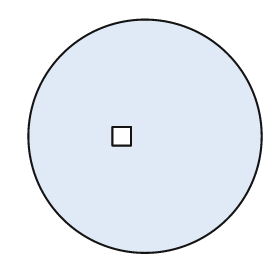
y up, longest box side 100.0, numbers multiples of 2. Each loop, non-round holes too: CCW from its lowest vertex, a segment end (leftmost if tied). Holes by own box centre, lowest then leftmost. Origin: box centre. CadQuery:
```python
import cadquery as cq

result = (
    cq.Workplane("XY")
    .moveTo(0.0, 0.0)
    .circle(50.0)
    .moveTo(-14.0, -4.0)
    .lineTo(-6.0, -4.0)
    .lineTo(-6.0, 4.0)
    .lineTo(-14.0, 4.0)
    .close()
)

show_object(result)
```